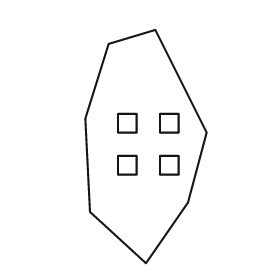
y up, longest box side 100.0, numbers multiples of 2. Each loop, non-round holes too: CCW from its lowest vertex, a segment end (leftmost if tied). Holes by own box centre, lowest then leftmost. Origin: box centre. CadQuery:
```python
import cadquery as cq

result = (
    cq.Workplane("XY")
    .moveTo(0.0, -50.0)
    .lineTo(18.0, -24.0)
    .lineTo(26.0, 6.0)
    .lineTo(4.0, 50.0)
    .lineTo(-16.0, 44.0)
    .lineTo(-26.0, 12.0)
    .lineTo(-24.0, -28.0)
    .close()
    .moveTo(-12.0, -12.0)
    .lineTo(-4.0, -12.0)
    .lineTo(-4.0, -4.0)
    .lineTo(-12.0, -4.0)
    .close()
    .moveTo(6.0, -12.0)
    .lineTo(14.0, -12.0)
    .lineTo(14.0, -4.0)
    .lineTo(6.0, -4.0)
    .close()
    .moveTo(-12.0, 6.0)
    .lineTo(-4.0, 6.0)
    .lineTo(-4.0, 14.0)
    .lineTo(-12.0, 14.0)
    .close()
    .moveTo(6.0, 6.0)
    .lineTo(14.0, 6.0)
    .lineTo(14.0, 14.0)
    .lineTo(6.0, 14.0)
    .close()
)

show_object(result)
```